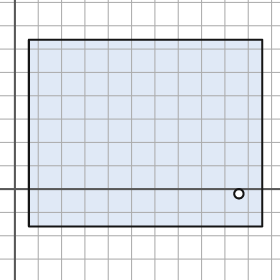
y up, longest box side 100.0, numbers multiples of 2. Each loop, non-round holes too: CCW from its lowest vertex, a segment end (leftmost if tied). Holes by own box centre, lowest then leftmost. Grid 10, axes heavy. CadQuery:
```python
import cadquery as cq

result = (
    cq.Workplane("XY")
    .moveTo(6.0, -16.0)
    .lineTo(106.0, -16.0)
    .lineTo(106.0, 64.0)
    .lineTo(6.0, 64.0)
    .close()
    .moveTo(96.0, -2.0)
    .circle(2.0)
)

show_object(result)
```